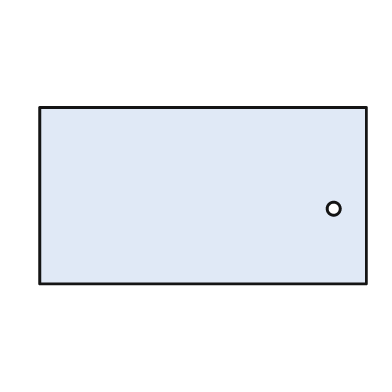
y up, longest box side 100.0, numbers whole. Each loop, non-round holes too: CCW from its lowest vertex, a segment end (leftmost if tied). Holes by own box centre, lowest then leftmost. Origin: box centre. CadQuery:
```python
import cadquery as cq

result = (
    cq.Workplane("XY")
    .moveTo(-50.0, -27.0)
    .lineTo(50.0, -27.0)
    .lineTo(50.0, 27.0)
    .lineTo(-50.0, 27.0)
    .close()
    .moveTo(40.0, -4.0)
    .circle(2.0)
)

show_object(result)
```